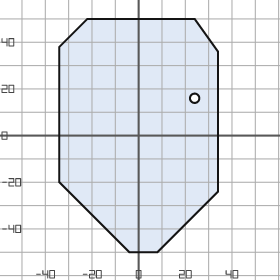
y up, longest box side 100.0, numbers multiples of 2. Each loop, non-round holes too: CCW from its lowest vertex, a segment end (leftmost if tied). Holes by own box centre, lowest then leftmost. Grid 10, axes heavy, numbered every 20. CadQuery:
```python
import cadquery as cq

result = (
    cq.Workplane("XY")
    .moveTo(-4.0, -50.0)
    .lineTo(8.0, -50.0)
    .lineTo(34.0, -24.0)
    .lineTo(34.0, 36.0)
    .lineTo(24.0, 50.0)
    .lineTo(-22.0, 50.0)
    .lineTo(-34.0, 38.0)
    .lineTo(-34.0, -20.0)
    .close()
    .moveTo(24.0, 16.0)
    .circle(2.0)
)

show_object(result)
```